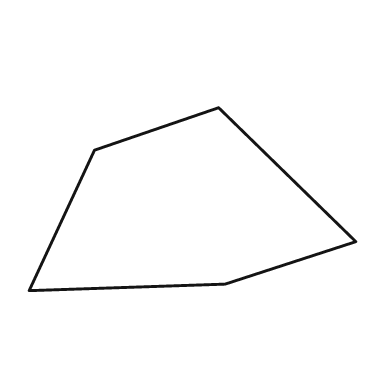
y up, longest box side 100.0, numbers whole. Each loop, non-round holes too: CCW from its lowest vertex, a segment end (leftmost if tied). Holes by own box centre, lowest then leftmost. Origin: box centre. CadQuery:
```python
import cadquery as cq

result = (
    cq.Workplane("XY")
    .moveTo(-50.0, -28.0)
    .lineTo(10.0, -26.0)
    .lineTo(50.0, -13.0)
    .lineTo(8.0, 28.0)
    .lineTo(-30.0, 15.0)
    .close()
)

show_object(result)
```